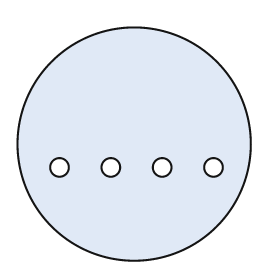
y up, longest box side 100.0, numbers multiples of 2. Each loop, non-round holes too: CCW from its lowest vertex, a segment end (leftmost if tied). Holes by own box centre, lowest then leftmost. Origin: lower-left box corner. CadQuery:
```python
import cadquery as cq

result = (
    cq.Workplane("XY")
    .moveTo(50.0, 50.0)
    .circle(50.0)
    .moveTo(18.0, 40.0)
    .circle(4.0)
    .moveTo(40.0, 40.0)
    .circle(4.0)
    .moveTo(62.0, 40.0)
    .circle(4.0)
    .moveTo(84.0, 40.0)
    .circle(4.0)
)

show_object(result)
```